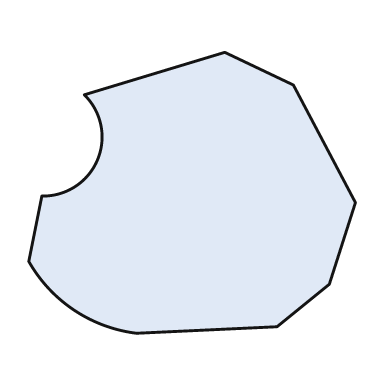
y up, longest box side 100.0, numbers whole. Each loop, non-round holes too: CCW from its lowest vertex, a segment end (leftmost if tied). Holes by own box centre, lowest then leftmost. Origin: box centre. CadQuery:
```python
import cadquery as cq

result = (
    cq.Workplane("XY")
    .moveTo(-17.0, -43.0)
    .lineTo(26.0, -41.0)
    .lineTo(42.0, -28.0)
    .lineTo(50.0, -3.0)
    .lineTo(31.0, 33.0)
    .lineTo(10.0, 43.0)
    .lineTo(-33.0, 30.0)
    .threePointArc((-29.0, 10.0), (-46.0, -1.0))
    .lineTo(-50.0, -21.0)
    .threePointArc((-36.0, -36.0), (-17.0, -43.0))
    .close()
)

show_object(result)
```